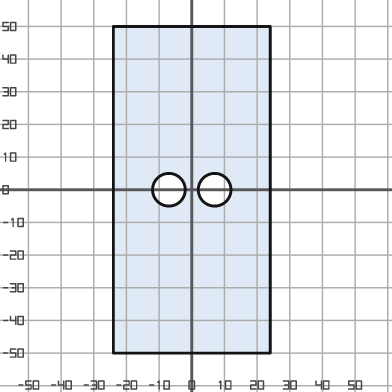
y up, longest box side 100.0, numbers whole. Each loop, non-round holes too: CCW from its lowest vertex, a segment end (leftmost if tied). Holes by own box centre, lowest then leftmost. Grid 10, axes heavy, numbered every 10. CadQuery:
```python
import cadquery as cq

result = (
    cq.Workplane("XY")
    .moveTo(-24.0, -50.0)
    .lineTo(24.0, -50.0)
    .lineTo(24.0, 50.0)
    .lineTo(-24.0, 50.0)
    .close()
    .moveTo(-7.0, 0.0)
    .circle(5.0)
    .moveTo(7.0, 0.0)
    .circle(5.0)
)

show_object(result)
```